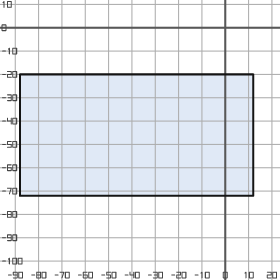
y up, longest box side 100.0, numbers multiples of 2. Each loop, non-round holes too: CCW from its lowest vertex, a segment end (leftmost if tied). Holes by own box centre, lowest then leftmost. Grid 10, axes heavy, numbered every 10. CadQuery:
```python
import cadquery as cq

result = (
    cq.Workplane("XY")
    .moveTo(-88.0, -72.0)
    .lineTo(12.0, -72.0)
    .lineTo(12.0, -20.0)
    .lineTo(-88.0, -20.0)
    .close()
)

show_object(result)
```